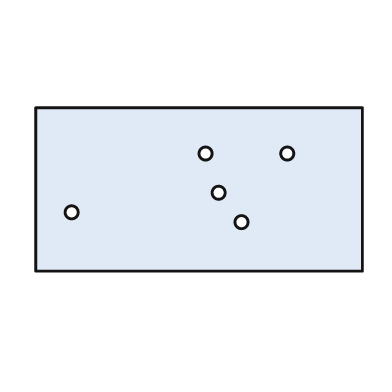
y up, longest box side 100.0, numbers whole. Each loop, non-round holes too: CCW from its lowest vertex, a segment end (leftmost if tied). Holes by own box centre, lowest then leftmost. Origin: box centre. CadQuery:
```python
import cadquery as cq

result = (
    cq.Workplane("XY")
    .moveTo(-50.0, -25.0)
    .lineTo(50.0, -25.0)
    .lineTo(50.0, 25.0)
    .lineTo(-50.0, 25.0)
    .close()
    .moveTo(13.0, -10.0)
    .circle(2.0)
    .moveTo(-39.0, -7.0)
    .circle(2.0)
    .moveTo(6.0, -1.0)
    .circle(2.0)
    .moveTo(2.0, 11.0)
    .circle(2.0)
    .moveTo(27.0, 11.0)
    .circle(2.0)
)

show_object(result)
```